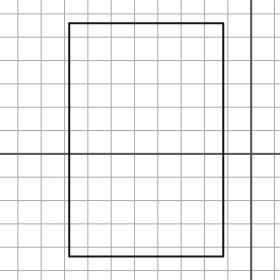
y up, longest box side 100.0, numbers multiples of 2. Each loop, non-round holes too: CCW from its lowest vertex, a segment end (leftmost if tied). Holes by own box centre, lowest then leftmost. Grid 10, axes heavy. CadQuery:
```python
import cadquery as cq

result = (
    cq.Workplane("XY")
    .moveTo(-78.0, -44.0)
    .lineTo(-12.0, -44.0)
    .lineTo(-12.0, 56.0)
    .lineTo(-78.0, 56.0)
    .close()
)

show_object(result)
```